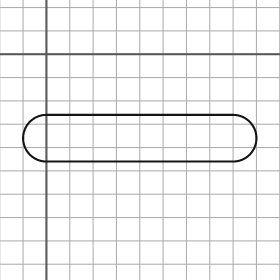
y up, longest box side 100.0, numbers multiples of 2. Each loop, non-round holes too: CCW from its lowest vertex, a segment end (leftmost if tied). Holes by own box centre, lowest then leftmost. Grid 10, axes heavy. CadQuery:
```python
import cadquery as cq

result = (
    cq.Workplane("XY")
    .moveTo(0.0, -46.0)
    .lineTo(80.0, -46.0)
    .threePointArc((90.0, -36.0), (80.0, -26.0))
    .lineTo(0.0, -26.0)
    .threePointArc((-10.0, -36.0), (0.0, -46.0))
    .close()
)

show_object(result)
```